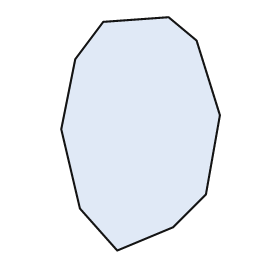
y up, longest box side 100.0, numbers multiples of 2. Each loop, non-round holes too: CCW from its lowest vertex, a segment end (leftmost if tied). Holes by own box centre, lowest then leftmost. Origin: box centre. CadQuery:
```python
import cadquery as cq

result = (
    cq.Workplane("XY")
    .moveTo(-10.0, -50.0)
    .lineTo(14.0, -40.0)
    .lineTo(28.0, -26.0)
    .lineTo(34.0, 8.0)
    .lineTo(24.0, 40.0)
    .lineTo(12.0, 50.0)
    .lineTo(-16.0, 48.0)
    .lineTo(-28.0, 32.0)
    .lineTo(-34.0, 2.0)
    .lineTo(-26.0, -32.0)
    .close()
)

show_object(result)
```